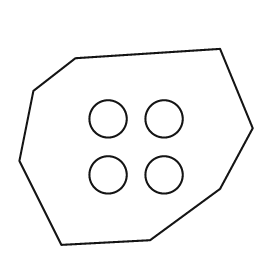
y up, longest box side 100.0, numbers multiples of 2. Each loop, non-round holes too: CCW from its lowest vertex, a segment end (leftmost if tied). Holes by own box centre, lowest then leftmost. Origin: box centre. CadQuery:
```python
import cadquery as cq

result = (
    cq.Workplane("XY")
    .moveTo(-32.0, -42.0)
    .lineTo(6.0, -40.0)
    .lineTo(36.0, -18.0)
    .lineTo(50.0, 8.0)
    .lineTo(36.0, 42.0)
    .lineTo(-26.0, 38.0)
    .lineTo(-44.0, 24.0)
    .lineTo(-50.0, -6.0)
    .close()
    .moveTo(-12.0, -12.0)
    .circle(8.0)
    .moveTo(12.0, -12.0)
    .circle(8.0)
    .moveTo(-12.0, 12.0)
    .circle(8.0)
    .moveTo(12.0, 12.0)
    .circle(8.0)
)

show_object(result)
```